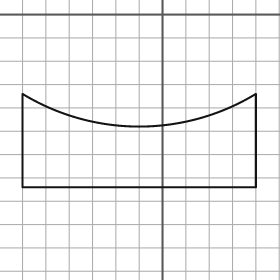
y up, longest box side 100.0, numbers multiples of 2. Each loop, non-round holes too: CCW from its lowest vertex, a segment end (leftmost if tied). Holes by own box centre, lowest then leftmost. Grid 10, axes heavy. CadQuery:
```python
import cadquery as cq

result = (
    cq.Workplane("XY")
    .moveTo(-60.0, -74.0)
    .lineTo(40.0, -74.0)
    .lineTo(40.0, -34.0)
    .threePointArc((-10.0, -48.0), (-60.0, -34.0))
    .close()
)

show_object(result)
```